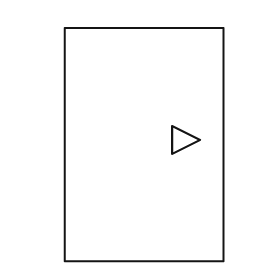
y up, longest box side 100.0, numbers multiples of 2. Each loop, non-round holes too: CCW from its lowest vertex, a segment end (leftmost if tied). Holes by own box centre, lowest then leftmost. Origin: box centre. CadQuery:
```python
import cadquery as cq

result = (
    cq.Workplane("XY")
    .moveTo(-34.0, -50.0)
    .lineTo(34.0, -50.0)
    .lineTo(34.0, 50.0)
    .lineTo(-34.0, 50.0)
    .close()
    .moveTo(12.0, -4.0)
    .lineTo(24.0, 2.0)
    .lineTo(12.0, 8.0)
    .close()
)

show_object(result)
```